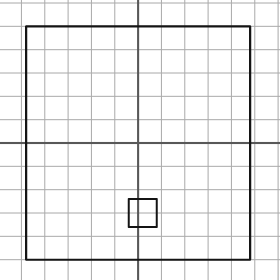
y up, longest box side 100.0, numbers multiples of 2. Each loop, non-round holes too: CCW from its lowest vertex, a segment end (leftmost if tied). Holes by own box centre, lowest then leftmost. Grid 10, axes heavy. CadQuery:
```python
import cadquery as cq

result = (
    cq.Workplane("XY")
    .moveTo(-48.0, -50.0)
    .lineTo(48.0, -50.0)
    .lineTo(48.0, 50.0)
    .lineTo(-48.0, 50.0)
    .close()
    .moveTo(-4.0, -36.0)
    .lineTo(8.0, -36.0)
    .lineTo(8.0, -24.0)
    .lineTo(-4.0, -24.0)
    .close()
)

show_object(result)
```